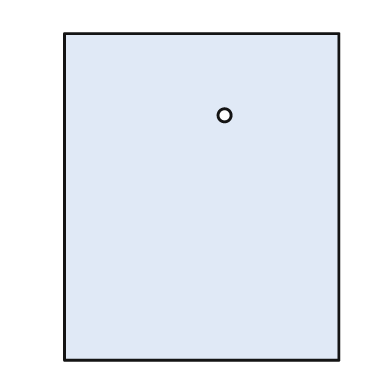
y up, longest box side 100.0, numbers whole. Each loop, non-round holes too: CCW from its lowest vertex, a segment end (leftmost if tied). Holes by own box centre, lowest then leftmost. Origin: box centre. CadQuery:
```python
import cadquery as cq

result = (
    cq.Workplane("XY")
    .moveTo(-42.0, -50.0)
    .lineTo(42.0, -50.0)
    .lineTo(42.0, 50.0)
    .lineTo(-42.0, 50.0)
    .close()
    .moveTo(7.0, 25.0)
    .circle(2.0)
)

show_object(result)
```